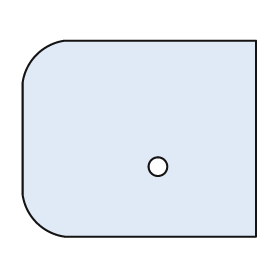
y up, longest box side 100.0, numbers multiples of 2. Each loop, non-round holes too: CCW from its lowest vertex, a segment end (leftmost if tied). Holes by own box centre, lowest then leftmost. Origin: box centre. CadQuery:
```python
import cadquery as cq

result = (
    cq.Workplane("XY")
    .moveTo(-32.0, -42.0)
    .lineTo(50.0, -42.0)
    .lineTo(50.0, 42.0)
    .lineTo(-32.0, 42.0)
    .threePointArc((-44.0, 36.0), (-50.0, 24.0))
    .lineTo(-50.0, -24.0)
    .threePointArc((-44.0, -36.0), (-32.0, -42.0))
    .close()
    .moveTo(8.0, -12.0)
    .circle(4.0)
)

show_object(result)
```